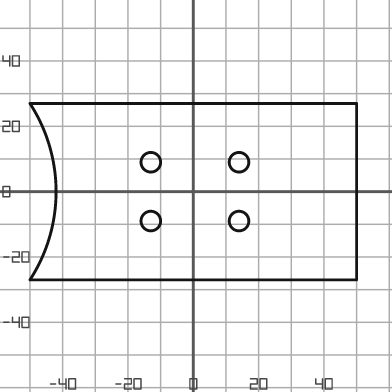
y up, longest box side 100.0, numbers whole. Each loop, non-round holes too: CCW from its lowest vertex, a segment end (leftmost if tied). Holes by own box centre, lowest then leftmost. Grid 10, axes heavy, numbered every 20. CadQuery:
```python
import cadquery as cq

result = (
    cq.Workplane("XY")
    .moveTo(-50.0, -27.0)
    .lineTo(50.0, -27.0)
    .lineTo(50.0, 27.0)
    .lineTo(-50.0, 27.0)
    .threePointArc((-42.0, 0.0), (-50.0, -27.0))
    .close()
    .moveTo(-13.0, -9.0)
    .circle(3.0)
    .moveTo(14.0, -9.0)
    .circle(3.0)
    .moveTo(-13.0, 9.0)
    .circle(3.0)
    .moveTo(14.0, 9.0)
    .circle(3.0)
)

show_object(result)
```